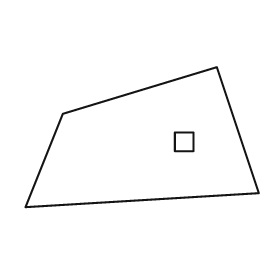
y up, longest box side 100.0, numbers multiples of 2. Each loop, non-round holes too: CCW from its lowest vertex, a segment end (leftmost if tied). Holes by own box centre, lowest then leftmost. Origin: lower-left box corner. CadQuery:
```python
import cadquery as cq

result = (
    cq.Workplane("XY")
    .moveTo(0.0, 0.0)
    .lineTo(100.0, 6.0)
    .lineTo(82.0, 60.0)
    .lineTo(16.0, 40.0)
    .close()
    .moveTo(64.0, 24.0)
    .lineTo(72.0, 24.0)
    .lineTo(72.0, 32.0)
    .lineTo(64.0, 32.0)
    .close()
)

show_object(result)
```